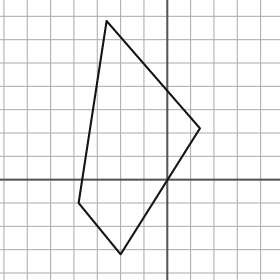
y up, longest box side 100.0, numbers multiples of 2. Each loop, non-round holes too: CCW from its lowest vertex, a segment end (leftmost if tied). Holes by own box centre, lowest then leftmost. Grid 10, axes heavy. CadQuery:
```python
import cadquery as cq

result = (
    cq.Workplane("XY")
    .moveTo(-20.0, -32.0)
    .lineTo(14.0, 22.0)
    .lineTo(-26.0, 68.0)
    .lineTo(-38.0, -10.0)
    .close()
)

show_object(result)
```